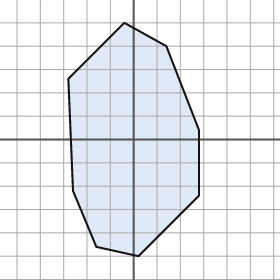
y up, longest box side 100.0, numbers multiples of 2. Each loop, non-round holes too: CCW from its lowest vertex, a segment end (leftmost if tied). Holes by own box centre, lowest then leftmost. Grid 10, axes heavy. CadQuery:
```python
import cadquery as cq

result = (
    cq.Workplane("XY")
    .moveTo(2.0, -50.0)
    .lineTo(28.0, -24.0)
    .lineTo(28.0, 4.0)
    .lineTo(14.0, 40.0)
    .lineTo(-4.0, 50.0)
    .lineTo(-28.0, 26.0)
    .lineTo(-26.0, -22.0)
    .lineTo(-16.0, -46.0)
    .close()
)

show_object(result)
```